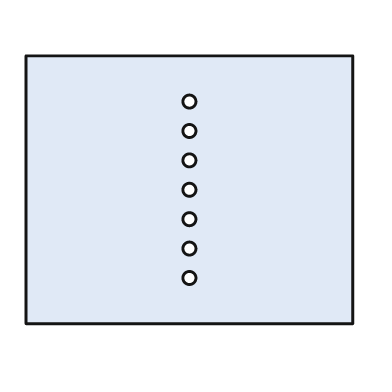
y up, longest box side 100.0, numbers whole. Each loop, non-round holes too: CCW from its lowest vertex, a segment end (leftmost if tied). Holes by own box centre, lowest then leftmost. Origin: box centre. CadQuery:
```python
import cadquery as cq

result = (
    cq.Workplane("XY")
    .moveTo(-50.0, -41.0)
    .lineTo(50.0, -41.0)
    .lineTo(50.0, 41.0)
    .lineTo(-50.0, 41.0)
    .close()
    .moveTo(0.0, -27.0)
    .circle(2.0)
    .moveTo(0.0, -18.0)
    .circle(2.0)
    .moveTo(0.0, -9.0)
    .circle(2.0)
    .moveTo(0.0, 0.0)
    .circle(2.0)
    .moveTo(0.0, 9.0)
    .circle(2.0)
    .moveTo(0.0, 18.0)
    .circle(2.0)
    .moveTo(0.0, 27.0)
    .circle(2.0)
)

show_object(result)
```